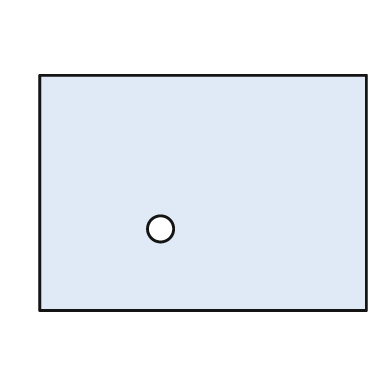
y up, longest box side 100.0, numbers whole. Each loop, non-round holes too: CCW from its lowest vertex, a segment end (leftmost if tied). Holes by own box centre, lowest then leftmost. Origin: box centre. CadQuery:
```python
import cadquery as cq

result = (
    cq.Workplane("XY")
    .moveTo(-50.0, -36.0)
    .lineTo(50.0, -36.0)
    .lineTo(50.0, 36.0)
    .lineTo(-50.0, 36.0)
    .close()
    .moveTo(-13.0, -11.0)
    .circle(4.0)
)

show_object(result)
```